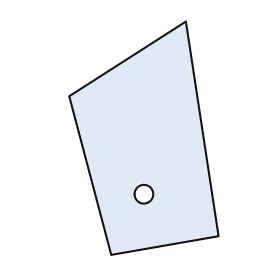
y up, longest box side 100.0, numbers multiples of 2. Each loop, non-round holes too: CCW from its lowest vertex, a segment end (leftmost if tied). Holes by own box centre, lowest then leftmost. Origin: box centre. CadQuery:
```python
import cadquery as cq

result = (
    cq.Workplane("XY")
    .moveTo(-14.0, -50.0)
    .lineTo(32.0, -42.0)
    .lineTo(18.0, 50.0)
    .lineTo(-32.0, 18.0)
    .close()
    .moveTo(0.0, -24.0)
    .circle(4.0)
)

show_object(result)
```